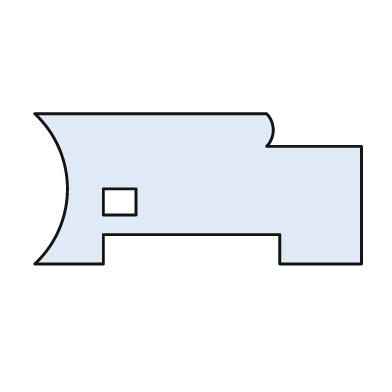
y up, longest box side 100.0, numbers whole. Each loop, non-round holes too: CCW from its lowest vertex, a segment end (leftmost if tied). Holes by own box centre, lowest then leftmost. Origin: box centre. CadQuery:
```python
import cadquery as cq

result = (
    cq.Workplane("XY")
    .moveTo(-50.0, -23.0)
    .lineTo(-29.0, -23.0)
    .lineTo(-29.0, -14.0)
    .lineTo(25.0, -14.0)
    .lineTo(25.0, -23.0)
    .lineTo(50.0, -23.0)
    .lineTo(50.0, 13.0)
    .lineTo(21.0, 13.0)
    .threePointArc((23.0, 18.0), (21.0, 23.0))
    .lineTo(-50.0, 23.0)
    .threePointArc((-40.0, 0.0), (-50.0, -23.0))
    .close()
    .moveTo(-29.0, -8.0)
    .lineTo(-19.0, -8.0)
    .lineTo(-19.0, 0.0)
    .lineTo(-29.0, 0.0)
    .close()
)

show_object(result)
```